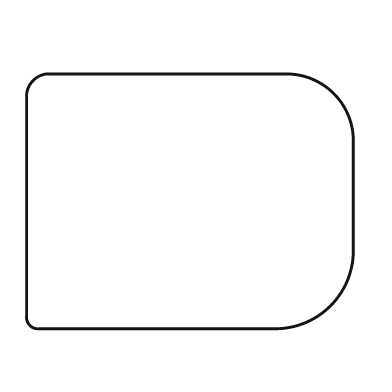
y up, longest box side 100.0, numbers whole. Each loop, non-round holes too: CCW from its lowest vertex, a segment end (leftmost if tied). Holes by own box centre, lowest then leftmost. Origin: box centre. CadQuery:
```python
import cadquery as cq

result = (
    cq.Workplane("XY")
    .moveTo(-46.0, -39.0)
    .lineTo(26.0, -39.0)
    .threePointArc((43.0, -32.0), (50.0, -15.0))
    .lineTo(50.0, 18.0)
    .threePointArc((44.0, 33.0), (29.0, 39.0))
    .lineTo(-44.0, 39.0)
    .threePointArc((-48.0, 37.0), (-50.0, 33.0))
    .lineTo(-50.0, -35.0)
    .threePointArc((-49.0, -38.0), (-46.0, -39.0))
    .close()
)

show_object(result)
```